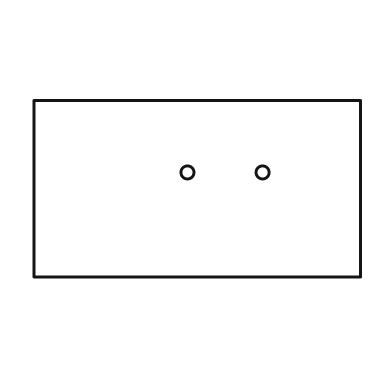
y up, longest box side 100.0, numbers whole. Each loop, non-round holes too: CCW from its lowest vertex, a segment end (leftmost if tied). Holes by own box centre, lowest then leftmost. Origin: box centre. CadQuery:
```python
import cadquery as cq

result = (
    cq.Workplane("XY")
    .moveTo(-50.0, -27.0)
    .lineTo(50.0, -27.0)
    .lineTo(50.0, 27.0)
    .lineTo(-50.0, 27.0)
    .close()
    .moveTo(-3.0, 5.0)
    .circle(2.0)
    .moveTo(20.0, 5.0)
    .circle(2.0)
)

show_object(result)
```